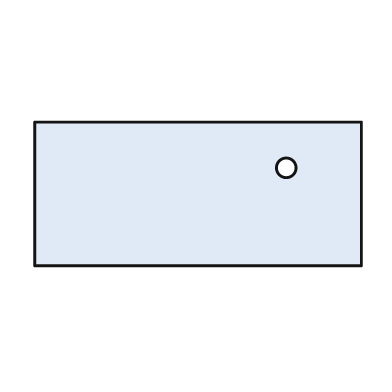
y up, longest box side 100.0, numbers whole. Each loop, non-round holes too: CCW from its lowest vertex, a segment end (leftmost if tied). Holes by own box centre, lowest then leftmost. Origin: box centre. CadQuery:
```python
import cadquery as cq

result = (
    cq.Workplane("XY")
    .moveTo(-50.0, -22.0)
    .lineTo(50.0, -22.0)
    .lineTo(50.0, 22.0)
    .lineTo(-50.0, 22.0)
    .close()
    .moveTo(27.0, 8.0)
    .circle(3.0)
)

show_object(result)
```